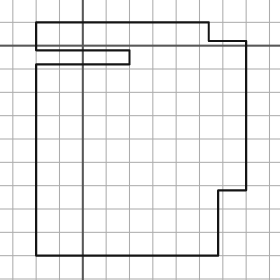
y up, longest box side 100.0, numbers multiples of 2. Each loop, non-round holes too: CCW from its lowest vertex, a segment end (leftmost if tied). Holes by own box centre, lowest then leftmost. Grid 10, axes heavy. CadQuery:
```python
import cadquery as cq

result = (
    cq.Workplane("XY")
    .moveTo(-20.0, -90.0)
    .lineTo(58.0, -90.0)
    .lineTo(58.0, -62.0)
    .lineTo(70.0, -62.0)
    .lineTo(70.0, 2.0)
    .lineTo(54.0, 2.0)
    .lineTo(54.0, 10.0)
    .lineTo(-20.0, 10.0)
    .lineTo(-20.0, -2.0)
    .lineTo(20.0, -2.0)
    .lineTo(20.0, -8.0)
    .lineTo(-20.0, -8.0)
    .close()
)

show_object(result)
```